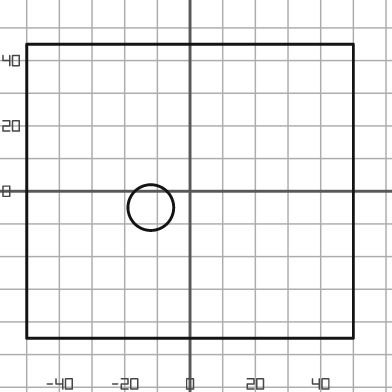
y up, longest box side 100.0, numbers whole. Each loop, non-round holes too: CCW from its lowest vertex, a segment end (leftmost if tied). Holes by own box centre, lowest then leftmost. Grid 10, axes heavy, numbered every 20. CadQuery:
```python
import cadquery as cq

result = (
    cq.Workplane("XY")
    .moveTo(-50.0, -45.0)
    .lineTo(50.0, -45.0)
    .lineTo(50.0, 45.0)
    .lineTo(-50.0, 45.0)
    .close()
    .moveTo(-12.0, -5.0)
    .circle(7.0)
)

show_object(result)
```